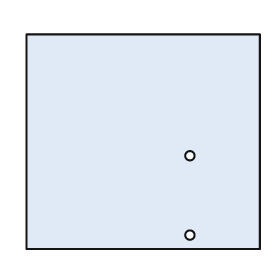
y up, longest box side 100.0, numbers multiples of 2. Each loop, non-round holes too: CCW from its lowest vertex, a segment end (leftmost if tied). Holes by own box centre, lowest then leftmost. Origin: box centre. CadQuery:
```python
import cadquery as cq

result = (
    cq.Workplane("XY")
    .moveTo(-50.0, -46.0)
    .lineTo(50.0, -46.0)
    .lineTo(50.0, 46.0)
    .lineTo(-50.0, 46.0)
    .close()
    .moveTo(20.0, -40.0)
    .circle(2.0)
    .moveTo(20.0, -6.0)
    .circle(2.0)
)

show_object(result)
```